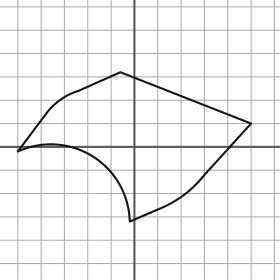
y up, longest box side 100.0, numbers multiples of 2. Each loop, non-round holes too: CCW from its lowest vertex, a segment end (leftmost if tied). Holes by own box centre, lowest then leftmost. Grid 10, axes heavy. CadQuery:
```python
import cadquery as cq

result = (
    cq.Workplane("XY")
    .moveTo(-2.0, -32.0)
    .lineTo(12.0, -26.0)
    .threePointArc((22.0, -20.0), (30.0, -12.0))
    .lineTo(50.0, 10.0)
    .lineTo(-6.0, 32.0)
    .lineTo(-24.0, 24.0)
    .threePointArc((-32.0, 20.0), (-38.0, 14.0))
    .lineTo(-50.0, -2.0)
    .threePointArc((-18.0, -4.0), (-2.0, -32.0))
    .close()
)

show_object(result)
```